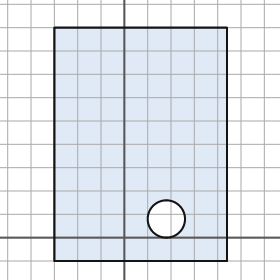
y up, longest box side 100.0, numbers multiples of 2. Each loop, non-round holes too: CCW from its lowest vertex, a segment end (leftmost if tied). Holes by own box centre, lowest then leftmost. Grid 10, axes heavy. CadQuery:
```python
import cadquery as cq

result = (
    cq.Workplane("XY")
    .moveTo(-30.0, -10.0)
    .lineTo(44.0, -10.0)
    .lineTo(44.0, 90.0)
    .lineTo(-30.0, 90.0)
    .close()
    .moveTo(18.0, 8.0)
    .circle(8.0)
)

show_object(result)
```